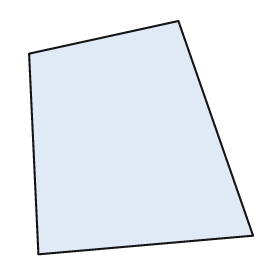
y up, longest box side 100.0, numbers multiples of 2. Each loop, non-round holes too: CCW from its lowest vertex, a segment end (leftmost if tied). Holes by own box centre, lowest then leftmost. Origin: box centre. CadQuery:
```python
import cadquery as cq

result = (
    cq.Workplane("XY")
    .moveTo(-44.0, -50.0)
    .lineTo(48.0, -42.0)
    .lineTo(16.0, 50.0)
    .lineTo(-48.0, 36.0)
    .close()
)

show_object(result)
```